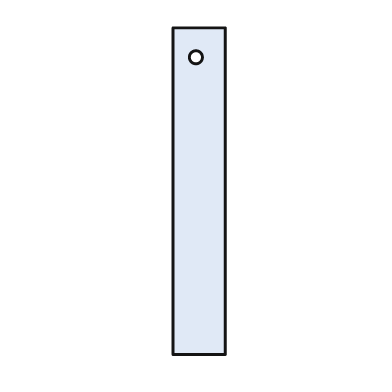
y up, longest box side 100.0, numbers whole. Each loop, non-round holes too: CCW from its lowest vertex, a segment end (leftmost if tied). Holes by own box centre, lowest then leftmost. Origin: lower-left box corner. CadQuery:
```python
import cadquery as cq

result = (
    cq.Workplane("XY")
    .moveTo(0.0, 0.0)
    .lineTo(16.0, 0.0)
    .lineTo(16.0, 100.0)
    .lineTo(0.0, 100.0)
    .close()
    .moveTo(7.0, 91.0)
    .circle(2.0)
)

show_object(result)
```